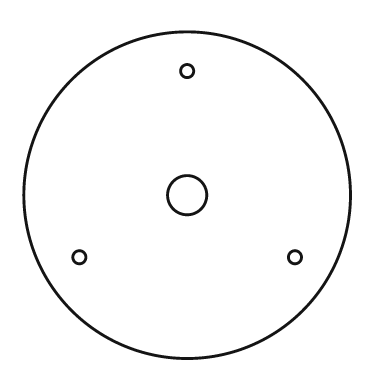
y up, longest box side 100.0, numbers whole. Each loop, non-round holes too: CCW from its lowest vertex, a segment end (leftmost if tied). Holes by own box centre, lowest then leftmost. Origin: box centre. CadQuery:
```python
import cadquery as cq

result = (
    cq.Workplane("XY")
    .moveTo(0.0, 0.0)
    .circle(50.0)
    .moveTo(-33.0, -19.0)
    .circle(2.0)
    .moveTo(33.0, -19.0)
    .circle(2.0)
    .moveTo(0.0, 0.0)
    .circle(6.0)
    .moveTo(0.0, 38.0)
    .circle(2.0)
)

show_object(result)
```